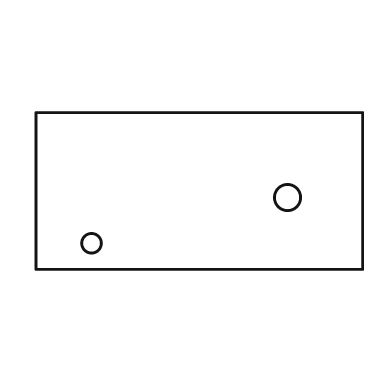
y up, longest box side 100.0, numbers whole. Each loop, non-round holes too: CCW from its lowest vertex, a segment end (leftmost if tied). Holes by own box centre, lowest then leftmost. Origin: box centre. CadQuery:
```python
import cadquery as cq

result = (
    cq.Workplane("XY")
    .moveTo(-50.0, -24.0)
    .lineTo(50.0, -24.0)
    .lineTo(50.0, 24.0)
    .lineTo(-50.0, 24.0)
    .close()
    .moveTo(-33.0, -16.0)
    .circle(3.0)
    .moveTo(27.0, -2.0)
    .circle(4.0)
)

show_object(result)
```